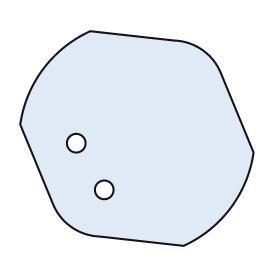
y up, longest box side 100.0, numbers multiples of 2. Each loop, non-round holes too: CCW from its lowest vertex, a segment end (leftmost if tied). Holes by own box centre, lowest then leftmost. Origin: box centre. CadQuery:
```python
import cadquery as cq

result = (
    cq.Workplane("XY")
    .moveTo(20.0, -46.0)
    .threePointArc((40.0, -30.0), (50.0, -6.0))
    .lineTo(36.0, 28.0)
    .threePointArc((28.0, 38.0), (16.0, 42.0))
    .lineTo(-20.0, 46.0)
    .threePointArc((-40.0, 30.0), (-50.0, 6.0))
    .lineTo(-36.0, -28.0)
    .threePointArc((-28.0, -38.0), (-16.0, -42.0))
    .close()
    .moveTo(-14.0, -22.0)
    .circle(4.0)
    .moveTo(-26.0, -2.0)
    .circle(4.0)
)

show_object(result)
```